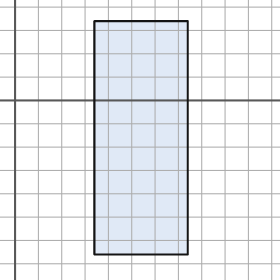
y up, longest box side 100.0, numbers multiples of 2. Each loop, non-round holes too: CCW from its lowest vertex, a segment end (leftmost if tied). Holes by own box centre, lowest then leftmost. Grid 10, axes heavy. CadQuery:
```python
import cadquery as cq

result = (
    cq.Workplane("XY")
    .moveTo(34.0, -66.0)
    .lineTo(74.0, -66.0)
    .lineTo(74.0, 34.0)
    .lineTo(34.0, 34.0)
    .close()
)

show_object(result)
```